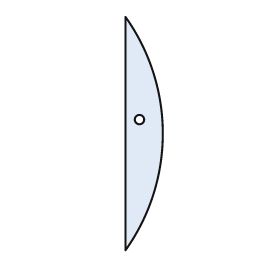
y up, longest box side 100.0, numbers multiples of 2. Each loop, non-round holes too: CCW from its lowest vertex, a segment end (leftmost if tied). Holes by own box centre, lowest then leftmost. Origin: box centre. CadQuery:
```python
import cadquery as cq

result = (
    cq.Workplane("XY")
    .moveTo(-8.0, -50.0)
    .threePointArc((8.0, 0.0), (-8.0, 50.0))
    .close()
    .moveTo(-2.0, 6.0)
    .circle(2.0)
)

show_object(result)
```